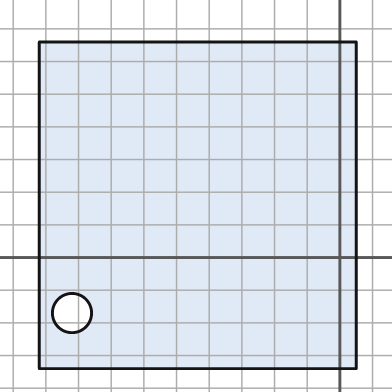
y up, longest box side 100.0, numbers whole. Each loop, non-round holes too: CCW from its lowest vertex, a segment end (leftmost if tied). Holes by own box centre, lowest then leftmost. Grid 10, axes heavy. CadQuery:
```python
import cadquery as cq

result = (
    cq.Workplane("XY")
    .moveTo(-92.0, -34.0)
    .lineTo(5.0, -34.0)
    .lineTo(5.0, 66.0)
    .lineTo(-92.0, 66.0)
    .close()
    .moveTo(-82.0, -17.0)
    .circle(6.0)
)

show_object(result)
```